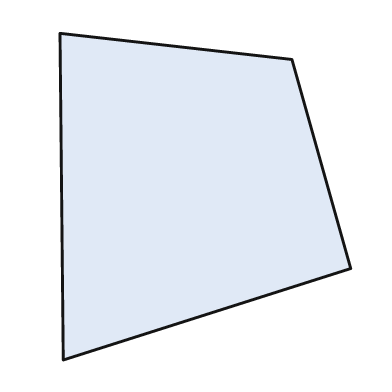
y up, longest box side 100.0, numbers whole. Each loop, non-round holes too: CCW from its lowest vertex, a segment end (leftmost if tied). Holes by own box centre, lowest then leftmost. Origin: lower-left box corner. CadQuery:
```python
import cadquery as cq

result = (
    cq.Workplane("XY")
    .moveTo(1.0, 0.0)
    .lineTo(89.0, 28.0)
    .lineTo(71.0, 92.0)
    .lineTo(0.0, 100.0)
    .close()
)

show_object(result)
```